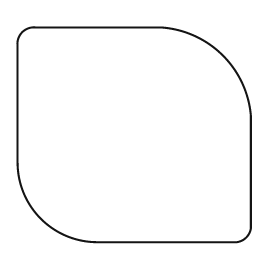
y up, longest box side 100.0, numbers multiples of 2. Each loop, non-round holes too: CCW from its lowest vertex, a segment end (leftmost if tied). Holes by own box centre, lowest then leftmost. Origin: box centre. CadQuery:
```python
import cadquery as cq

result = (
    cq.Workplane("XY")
    .moveTo(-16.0, -46.0)
    .lineTo(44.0, -46.0)
    .threePointArc((48.0, -44.0), (50.0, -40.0))
    .lineTo(50.0, 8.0)
    .threePointArc((38.0, 34.0), (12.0, 46.0))
    .lineTo(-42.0, 46.0)
    .threePointArc((-48.0, 44.0), (-50.0, 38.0))
    .lineTo(-50.0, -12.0)
    .threePointArc((-40.0, -36.0), (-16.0, -46.0))
    .close()
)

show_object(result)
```